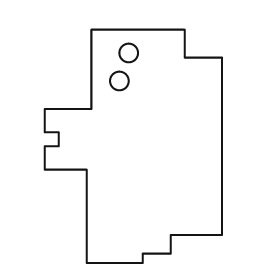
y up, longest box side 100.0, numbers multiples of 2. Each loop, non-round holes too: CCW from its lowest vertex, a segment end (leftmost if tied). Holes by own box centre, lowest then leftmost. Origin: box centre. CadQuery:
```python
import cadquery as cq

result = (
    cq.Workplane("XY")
    .moveTo(-20.0, -50.0)
    .lineTo(4.0, -50.0)
    .lineTo(4.0, -46.0)
    .lineTo(16.0, -46.0)
    .lineTo(16.0, -38.0)
    .lineTo(38.0, -38.0)
    .lineTo(38.0, 38.0)
    .lineTo(22.0, 38.0)
    .lineTo(22.0, 50.0)
    .lineTo(-18.0, 50.0)
    .lineTo(-18.0, 16.0)
    .lineTo(-38.0, 16.0)
    .lineTo(-38.0, 6.0)
    .lineTo(-32.0, 6.0)
    .lineTo(-32.0, 0.0)
    .lineTo(-38.0, 0.0)
    .lineTo(-38.0, -10.0)
    .lineTo(-20.0, -10.0)
    .close()
    .moveTo(-6.0, 28.0)
    .circle(4.0)
    .moveTo(-2.0, 40.0)
    .circle(4.0)
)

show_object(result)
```